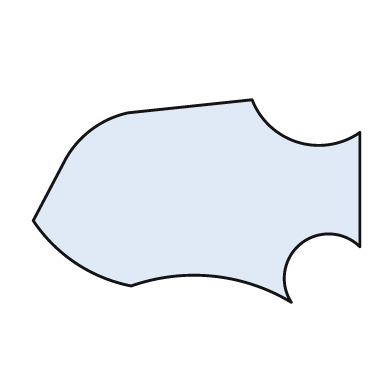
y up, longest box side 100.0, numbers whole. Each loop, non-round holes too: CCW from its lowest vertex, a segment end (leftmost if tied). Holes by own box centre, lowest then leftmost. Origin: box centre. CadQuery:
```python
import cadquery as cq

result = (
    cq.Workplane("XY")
    .moveTo(29.0, -31.0)
    .threePointArc((32.0, -13.0), (50.0, -14.0))
    .lineTo(50.0, 21.0)
    .threePointArc((31.0, 18.0), (17.0, 31.0))
    .lineTo(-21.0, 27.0)
    .threePointArc((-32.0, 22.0), (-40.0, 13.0))
    .lineTo(-50.0, -6.0)
    .threePointArc((-37.0, -19.0), (-20.0, -26.0))
    .threePointArc((5.0, -23.0), (29.0, -31.0))
    .close()
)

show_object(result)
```